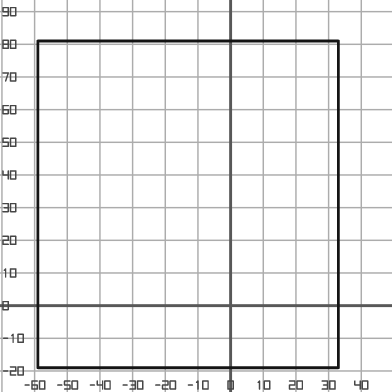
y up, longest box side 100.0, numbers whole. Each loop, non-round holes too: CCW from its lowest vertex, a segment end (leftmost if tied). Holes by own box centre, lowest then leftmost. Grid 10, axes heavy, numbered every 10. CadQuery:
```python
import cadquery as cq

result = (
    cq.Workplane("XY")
    .moveTo(-59.0, -19.0)
    .lineTo(33.0, -19.0)
    .lineTo(33.0, 81.0)
    .lineTo(-59.0, 81.0)
    .close()
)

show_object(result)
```